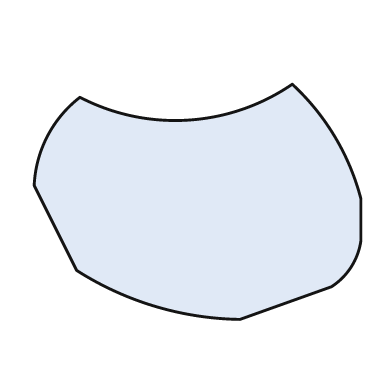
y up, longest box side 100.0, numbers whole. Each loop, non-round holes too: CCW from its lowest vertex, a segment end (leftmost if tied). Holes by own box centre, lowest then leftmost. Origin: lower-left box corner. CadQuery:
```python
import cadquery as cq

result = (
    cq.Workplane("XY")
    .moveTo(63.0, 0.0)
    .lineTo(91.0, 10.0)
    .threePointArc((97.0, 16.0), (100.0, 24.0))
    .lineTo(100.0, 37.0)
    .threePointArc((92.0, 56.0), (79.0, 72.0))
    .threePointArc((47.0, 61.0), (14.0, 68.0))
    .threePointArc((4.0, 56.0), (0.0, 41.0))
    .lineTo(13.0, 15.0)
    .threePointArc((37.0, 4.0), (63.0, 0.0))
    .close()
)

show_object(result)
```